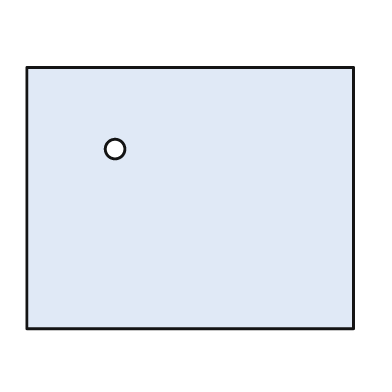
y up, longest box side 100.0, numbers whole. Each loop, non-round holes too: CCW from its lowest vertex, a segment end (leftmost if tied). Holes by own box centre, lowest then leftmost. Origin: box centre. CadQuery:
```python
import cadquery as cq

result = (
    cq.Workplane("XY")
    .moveTo(-50.0, -40.0)
    .lineTo(50.0, -40.0)
    .lineTo(50.0, 40.0)
    .lineTo(-50.0, 40.0)
    .close()
    .moveTo(-23.0, 15.0)
    .circle(3.0)
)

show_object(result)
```